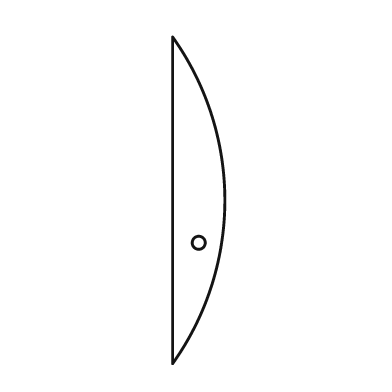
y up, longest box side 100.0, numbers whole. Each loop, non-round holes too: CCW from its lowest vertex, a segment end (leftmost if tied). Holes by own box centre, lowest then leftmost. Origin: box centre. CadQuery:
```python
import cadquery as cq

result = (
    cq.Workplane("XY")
    .moveTo(-8.0, -50.0)
    .threePointArc((8.0, 0.0), (-8.0, 50.0))
    .close()
    .moveTo(0.0, -13.0)
    .circle(2.0)
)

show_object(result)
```